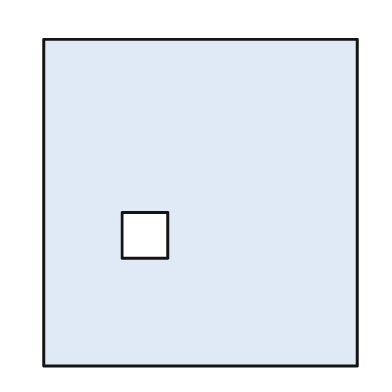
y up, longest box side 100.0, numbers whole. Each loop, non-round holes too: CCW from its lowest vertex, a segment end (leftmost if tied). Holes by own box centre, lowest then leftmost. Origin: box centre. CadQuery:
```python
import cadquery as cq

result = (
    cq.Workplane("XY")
    .moveTo(-48.0, -50.0)
    .lineTo(48.0, -50.0)
    .lineTo(48.0, 50.0)
    .lineTo(-48.0, 50.0)
    .close()
    .moveTo(-24.0, -17.0)
    .lineTo(-10.0, -17.0)
    .lineTo(-10.0, -3.0)
    .lineTo(-24.0, -3.0)
    .close()
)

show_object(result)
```